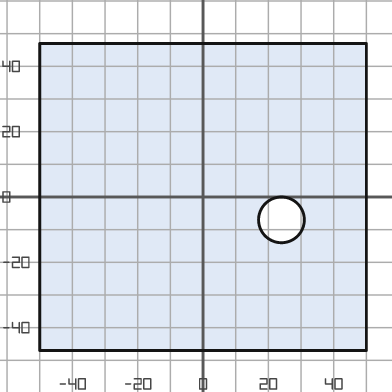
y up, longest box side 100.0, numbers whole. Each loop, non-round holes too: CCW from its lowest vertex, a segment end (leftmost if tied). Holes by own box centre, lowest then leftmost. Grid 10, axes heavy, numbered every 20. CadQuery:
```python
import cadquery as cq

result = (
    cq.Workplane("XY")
    .moveTo(-50.0, -47.0)
    .lineTo(50.0, -47.0)
    .lineTo(50.0, 47.0)
    .lineTo(-50.0, 47.0)
    .close()
    .moveTo(24.0, -7.0)
    .circle(7.0)
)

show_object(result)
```